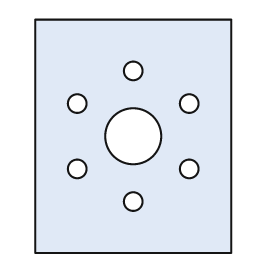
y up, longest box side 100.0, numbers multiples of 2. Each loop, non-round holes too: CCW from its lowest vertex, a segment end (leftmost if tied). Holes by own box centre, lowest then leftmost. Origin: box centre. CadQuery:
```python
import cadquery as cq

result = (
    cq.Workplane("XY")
    .moveTo(-42.0, -50.0)
    .lineTo(42.0, -50.0)
    .lineTo(42.0, 50.0)
    .lineTo(-42.0, 50.0)
    .close()
    .moveTo(0.0, -28.0)
    .circle(4.0)
    .moveTo(-24.0, -14.0)
    .circle(4.0)
    .moveTo(24.0, -14.0)
    .circle(4.0)
    .moveTo(0.0, 0.0)
    .circle(12.0)
    .moveTo(-24.0, 14.0)
    .circle(4.0)
    .moveTo(24.0, 14.0)
    .circle(4.0)
    .moveTo(0.0, 28.0)
    .circle(4.0)
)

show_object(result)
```